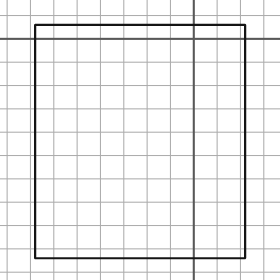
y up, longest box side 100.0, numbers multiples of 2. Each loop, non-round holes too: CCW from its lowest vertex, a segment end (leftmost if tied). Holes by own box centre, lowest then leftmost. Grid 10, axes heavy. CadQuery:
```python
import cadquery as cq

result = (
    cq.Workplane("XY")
    .moveTo(-68.0, -94.0)
    .lineTo(22.0, -94.0)
    .lineTo(22.0, 6.0)
    .lineTo(-68.0, 6.0)
    .close()
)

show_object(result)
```